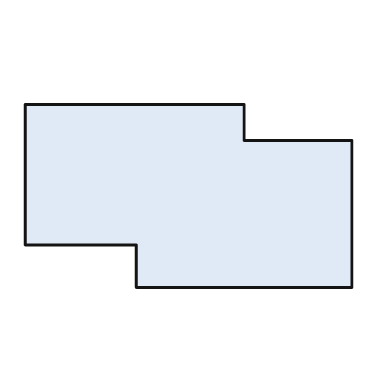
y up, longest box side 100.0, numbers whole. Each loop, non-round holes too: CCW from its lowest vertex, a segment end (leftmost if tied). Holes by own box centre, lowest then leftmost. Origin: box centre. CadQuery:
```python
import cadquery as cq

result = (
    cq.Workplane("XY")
    .moveTo(-16.0, -28.0)
    .lineTo(50.0, -28.0)
    .lineTo(50.0, 17.0)
    .lineTo(17.0, 17.0)
    .lineTo(17.0, 28.0)
    .lineTo(-50.0, 28.0)
    .lineTo(-50.0, -15.0)
    .lineTo(-16.0, -15.0)
    .close()
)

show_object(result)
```